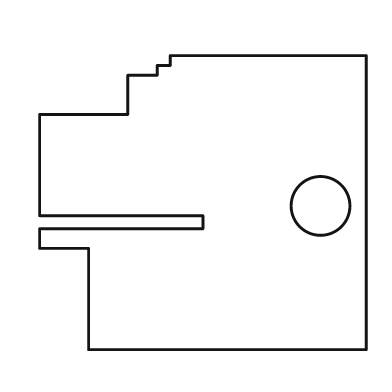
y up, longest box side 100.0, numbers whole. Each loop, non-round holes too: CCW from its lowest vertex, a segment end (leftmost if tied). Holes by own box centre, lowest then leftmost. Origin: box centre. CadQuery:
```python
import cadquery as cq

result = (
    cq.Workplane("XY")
    .moveTo(-35.0, -45.0)
    .lineTo(50.0, -45.0)
    .lineTo(50.0, 45.0)
    .lineTo(-10.0, 45.0)
    .lineTo(-10.0, 42.0)
    .lineTo(-14.0, 42.0)
    .lineTo(-14.0, 39.0)
    .lineTo(-23.0, 39.0)
    .lineTo(-23.0, 27.0)
    .lineTo(-50.0, 27.0)
    .lineTo(-50.0, -4.0)
    .lineTo(0.0, -4.0)
    .lineTo(0.0, -8.0)
    .lineTo(-50.0, -8.0)
    .lineTo(-50.0, -14.0)
    .lineTo(-35.0, -14.0)
    .close()
    .moveTo(36.0, -1.0)
    .circle(9.0)
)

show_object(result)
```